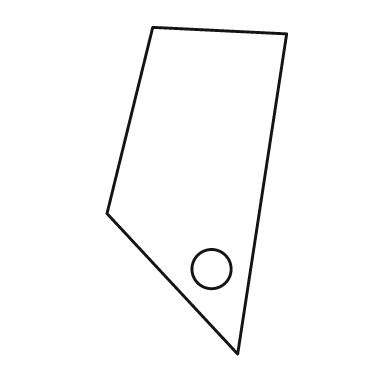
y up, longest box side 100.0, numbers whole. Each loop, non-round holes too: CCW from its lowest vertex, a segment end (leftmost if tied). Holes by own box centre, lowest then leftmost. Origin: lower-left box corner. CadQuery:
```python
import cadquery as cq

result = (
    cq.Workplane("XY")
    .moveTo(40.0, 0.0)
    .lineTo(55.0, 98.0)
    .lineTo(14.0, 100.0)
    .lineTo(0.0, 43.0)
    .close()
    .moveTo(32.0, 26.0)
    .circle(6.0)
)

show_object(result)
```